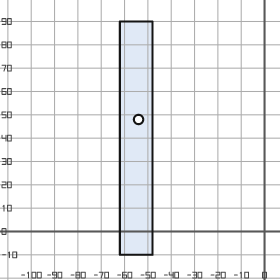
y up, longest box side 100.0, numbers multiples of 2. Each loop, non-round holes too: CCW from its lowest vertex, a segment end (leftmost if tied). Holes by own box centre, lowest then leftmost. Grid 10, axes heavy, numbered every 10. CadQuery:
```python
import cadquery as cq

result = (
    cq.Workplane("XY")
    .moveTo(-62.0, -10.0)
    .lineTo(-48.0, -10.0)
    .lineTo(-48.0, 90.0)
    .lineTo(-62.0, 90.0)
    .close()
    .moveTo(-54.0, 48.0)
    .circle(2.0)
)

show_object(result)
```